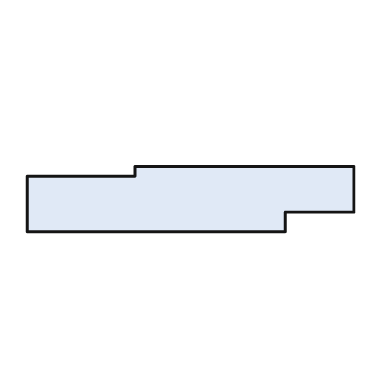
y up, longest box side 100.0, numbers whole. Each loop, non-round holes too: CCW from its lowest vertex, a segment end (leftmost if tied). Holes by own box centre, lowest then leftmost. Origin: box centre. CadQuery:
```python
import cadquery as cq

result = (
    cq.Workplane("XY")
    .moveTo(-50.0, -10.0)
    .lineTo(29.0, -10.0)
    .lineTo(29.0, -4.0)
    .lineTo(50.0, -4.0)
    .lineTo(50.0, 10.0)
    .lineTo(-17.0, 10.0)
    .lineTo(-17.0, 7.0)
    .lineTo(-50.0, 7.0)
    .close()
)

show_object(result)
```